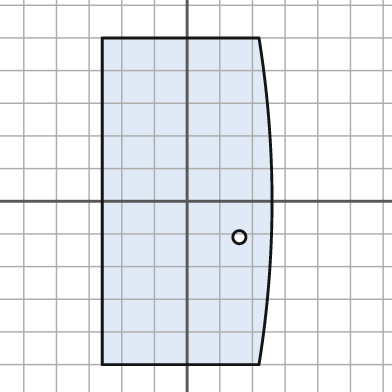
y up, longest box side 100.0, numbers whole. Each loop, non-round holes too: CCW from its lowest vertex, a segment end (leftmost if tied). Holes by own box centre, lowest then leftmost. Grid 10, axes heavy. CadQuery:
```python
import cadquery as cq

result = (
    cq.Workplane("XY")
    .moveTo(-26.0, -50.0)
    .lineTo(22.0, -50.0)
    .threePointArc((26.0, 0.0), (22.0, 50.0))
    .lineTo(-26.0, 50.0)
    .close()
    .moveTo(16.0, -11.0)
    .circle(2.0)
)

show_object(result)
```